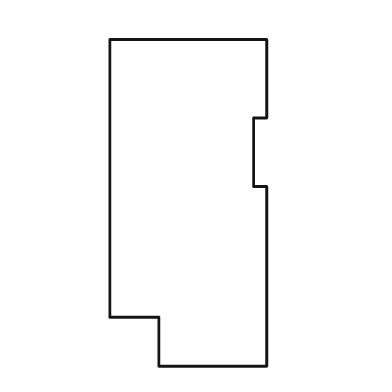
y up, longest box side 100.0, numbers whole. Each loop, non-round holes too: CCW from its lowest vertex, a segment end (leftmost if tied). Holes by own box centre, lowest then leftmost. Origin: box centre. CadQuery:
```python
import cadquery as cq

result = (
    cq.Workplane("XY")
    .moveTo(-9.0, -50.0)
    .lineTo(24.0, -50.0)
    .lineTo(24.0, 5.0)
    .lineTo(20.0, 5.0)
    .lineTo(20.0, 26.0)
    .lineTo(24.0, 26.0)
    .lineTo(24.0, 50.0)
    .lineTo(-24.0, 50.0)
    .lineTo(-24.0, -35.0)
    .lineTo(-9.0, -35.0)
    .close()
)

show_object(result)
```